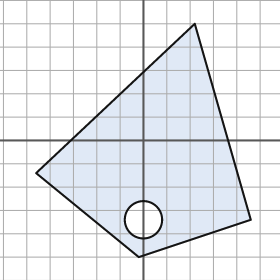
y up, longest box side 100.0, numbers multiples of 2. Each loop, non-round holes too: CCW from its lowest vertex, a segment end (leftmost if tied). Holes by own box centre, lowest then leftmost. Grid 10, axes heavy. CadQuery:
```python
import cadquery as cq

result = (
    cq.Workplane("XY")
    .moveTo(-2.0, -50.0)
    .lineTo(46.0, -34.0)
    .lineTo(22.0, 50.0)
    .lineTo(-46.0, -14.0)
    .close()
    .moveTo(0.0, -34.0)
    .circle(8.0)
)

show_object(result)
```